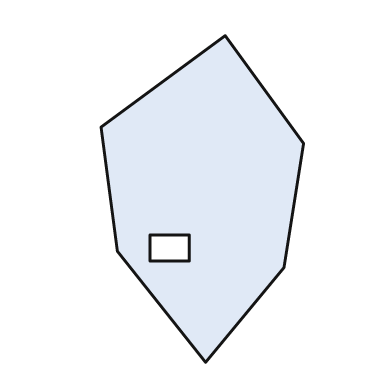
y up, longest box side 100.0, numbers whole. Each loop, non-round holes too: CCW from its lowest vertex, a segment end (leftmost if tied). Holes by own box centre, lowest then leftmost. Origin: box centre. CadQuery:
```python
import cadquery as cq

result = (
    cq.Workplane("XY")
    .moveTo(1.0, -50.0)
    .lineTo(25.0, -21.0)
    .lineTo(31.0, 17.0)
    .lineTo(7.0, 50.0)
    .lineTo(-31.0, 22.0)
    .lineTo(-26.0, -16.0)
    .close()
    .moveTo(-16.0, -19.0)
    .lineTo(-4.0, -19.0)
    .lineTo(-4.0, -11.0)
    .lineTo(-16.0, -11.0)
    .close()
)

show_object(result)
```